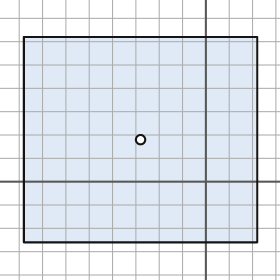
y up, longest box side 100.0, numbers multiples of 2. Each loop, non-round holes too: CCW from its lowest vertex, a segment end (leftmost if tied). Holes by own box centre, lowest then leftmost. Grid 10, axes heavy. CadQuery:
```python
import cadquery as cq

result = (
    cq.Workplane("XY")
    .moveTo(-78.0, -26.0)
    .lineTo(22.0, -26.0)
    .lineTo(22.0, 62.0)
    .lineTo(-78.0, 62.0)
    .close()
    .moveTo(-28.0, 18.0)
    .circle(2.0)
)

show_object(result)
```